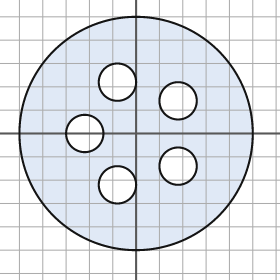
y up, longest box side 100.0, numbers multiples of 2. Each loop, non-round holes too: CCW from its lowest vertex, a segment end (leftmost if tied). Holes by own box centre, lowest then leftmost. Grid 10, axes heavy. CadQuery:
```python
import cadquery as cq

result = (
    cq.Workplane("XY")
    .moveTo(0.0, 0.0)
    .circle(50.0)
    .moveTo(-8.0, -22.0)
    .circle(8.0)
    .moveTo(18.0, -14.0)
    .circle(8.0)
    .moveTo(-22.0, 0.0)
    .circle(8.0)
    .moveTo(18.0, 14.0)
    .circle(8.0)
    .moveTo(-8.0, 22.0)
    .circle(8.0)
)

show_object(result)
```